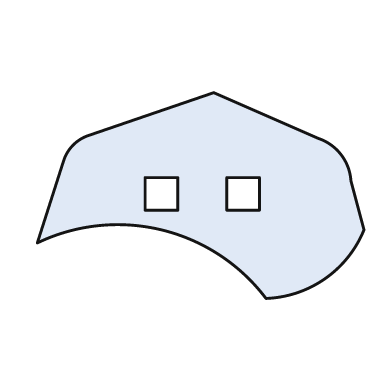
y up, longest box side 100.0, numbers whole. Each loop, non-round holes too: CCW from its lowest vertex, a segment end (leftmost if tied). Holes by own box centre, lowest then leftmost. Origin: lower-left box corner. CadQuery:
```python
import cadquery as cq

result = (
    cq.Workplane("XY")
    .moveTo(70.0, 0.0)
    .threePointArc((88.0, 6.0), (100.0, 21.0))
    .lineTo(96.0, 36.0)
    .threePointArc((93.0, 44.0), (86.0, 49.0))
    .lineTo(54.0, 63.0)
    .lineTo(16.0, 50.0)
    .threePointArc((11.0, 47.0), (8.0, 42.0))
    .lineTo(0.0, 17.0)
    .threePointArc((38.0, 21.0), (70.0, 0.0))
    .close()
    .moveTo(33.0, 27.0)
    .lineTo(43.0, 27.0)
    .lineTo(43.0, 37.0)
    .lineTo(33.0, 37.0)
    .close()
    .moveTo(58.0, 27.0)
    .lineTo(68.0, 27.0)
    .lineTo(68.0, 37.0)
    .lineTo(58.0, 37.0)
    .close()
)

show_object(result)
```